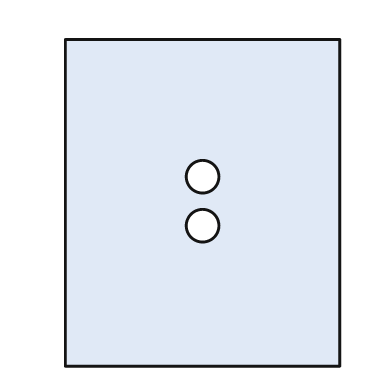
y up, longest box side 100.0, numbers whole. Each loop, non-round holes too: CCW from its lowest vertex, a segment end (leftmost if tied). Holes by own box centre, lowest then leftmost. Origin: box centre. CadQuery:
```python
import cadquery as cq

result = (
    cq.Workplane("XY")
    .moveTo(-42.0, -50.0)
    .lineTo(42.0, -50.0)
    .lineTo(42.0, 50.0)
    .lineTo(-42.0, 50.0)
    .close()
    .moveTo(0.0, -7.0)
    .circle(5.0)
    .moveTo(0.0, 8.0)
    .circle(5.0)
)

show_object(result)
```